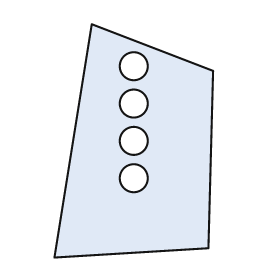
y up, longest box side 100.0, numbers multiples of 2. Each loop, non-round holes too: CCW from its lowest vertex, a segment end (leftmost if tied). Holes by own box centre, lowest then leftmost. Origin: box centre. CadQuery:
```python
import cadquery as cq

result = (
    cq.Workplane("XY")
    .moveTo(-34.0, -50.0)
    .lineTo(32.0, -46.0)
    .lineTo(34.0, 30.0)
    .lineTo(-18.0, 50.0)
    .close()
    .moveTo(0.0, -16.0)
    .circle(6.0)
    .moveTo(0.0, 0.0)
    .circle(6.0)
    .moveTo(0.0, 16.0)
    .circle(6.0)
    .moveTo(0.0, 32.0)
    .circle(6.0)
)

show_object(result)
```